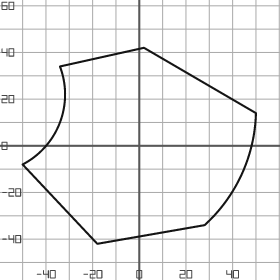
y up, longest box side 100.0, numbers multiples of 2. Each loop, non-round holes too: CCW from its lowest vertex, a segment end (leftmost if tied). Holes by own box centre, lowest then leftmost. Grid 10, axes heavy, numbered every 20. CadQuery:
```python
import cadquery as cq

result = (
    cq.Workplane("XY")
    .moveTo(-18.0, -42.0)
    .lineTo(28.0, -34.0)
    .threePointArc((44.0, -12.0), (50.0, 14.0))
    .lineTo(2.0, 42.0)
    .lineTo(-34.0, 34.0)
    .threePointArc((-34.0, 10.0), (-50.0, -8.0))
    .close()
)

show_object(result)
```